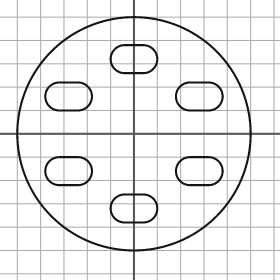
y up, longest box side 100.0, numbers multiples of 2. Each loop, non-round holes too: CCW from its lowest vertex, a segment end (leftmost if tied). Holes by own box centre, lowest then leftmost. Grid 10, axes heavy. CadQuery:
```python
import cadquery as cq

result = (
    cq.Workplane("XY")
    .moveTo(0.0, 0.0)
    .circle(50.0)
    .moveTo(-4.0, -38.0)
    .lineTo(4.0, -38.0)
    .threePointArc((10.0, -32.0), (4.0, -26.0))
    .lineTo(-4.0, -26.0)
    .threePointArc((-10.0, -32.0), (-4.0, -38.0))
    .close()
    .moveTo(-32.0, -22.0)
    .lineTo(-24.0, -22.0)
    .threePointArc((-18.0, -16.0), (-24.0, -10.0))
    .lineTo(-32.0, -10.0)
    .threePointArc((-38.0, -16.0), (-32.0, -22.0))
    .close()
    .moveTo(24.0, -22.0)
    .lineTo(32.0, -22.0)
    .threePointArc((38.0, -16.0), (32.0, -10.0))
    .lineTo(24.0, -10.0)
    .threePointArc((18.0, -16.0), (24.0, -22.0))
    .close()
    .moveTo(-32.0, 10.0)
    .lineTo(-24.0, 10.0)
    .threePointArc((-18.0, 16.0), (-24.0, 22.0))
    .lineTo(-32.0, 22.0)
    .threePointArc((-38.0, 16.0), (-32.0, 10.0))
    .close()
    .moveTo(24.0, 10.0)
    .lineTo(32.0, 10.0)
    .threePointArc((38.0, 16.0), (32.0, 22.0))
    .lineTo(24.0, 22.0)
    .threePointArc((18.0, 16.0), (24.0, 10.0))
    .close()
    .moveTo(-4.0, 26.0)
    .lineTo(4.0, 26.0)
    .threePointArc((10.0, 32.0), (4.0, 38.0))
    .lineTo(-4.0, 38.0)
    .threePointArc((-10.0, 32.0), (-4.0, 26.0))
    .close()
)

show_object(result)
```